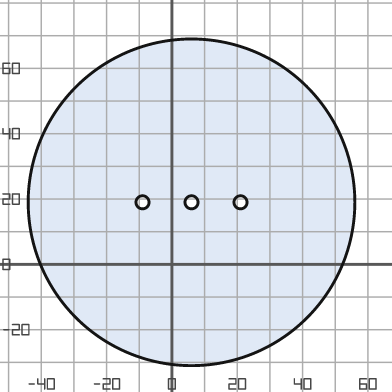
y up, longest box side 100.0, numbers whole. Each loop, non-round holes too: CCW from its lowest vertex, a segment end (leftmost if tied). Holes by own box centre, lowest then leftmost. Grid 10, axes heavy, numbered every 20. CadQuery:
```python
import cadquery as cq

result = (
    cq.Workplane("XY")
    .moveTo(6.0, 19.0)
    .circle(50.0)
    .moveTo(-9.0, 19.0)
    .circle(2.0)
    .moveTo(6.0, 19.0)
    .circle(2.0)
    .moveTo(21.0, 19.0)
    .circle(2.0)
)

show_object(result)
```